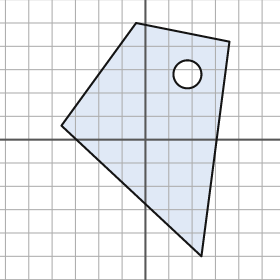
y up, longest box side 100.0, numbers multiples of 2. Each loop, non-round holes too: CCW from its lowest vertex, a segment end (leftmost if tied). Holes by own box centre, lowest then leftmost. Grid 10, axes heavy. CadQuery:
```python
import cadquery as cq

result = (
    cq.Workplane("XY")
    .moveTo(24.0, -50.0)
    .lineTo(36.0, 42.0)
    .lineTo(-4.0, 50.0)
    .lineTo(-36.0, 6.0)
    .close()
    .moveTo(18.0, 28.0)
    .circle(6.0)
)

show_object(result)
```